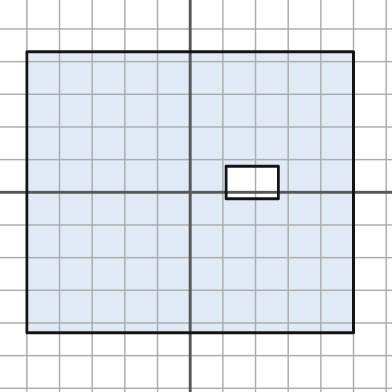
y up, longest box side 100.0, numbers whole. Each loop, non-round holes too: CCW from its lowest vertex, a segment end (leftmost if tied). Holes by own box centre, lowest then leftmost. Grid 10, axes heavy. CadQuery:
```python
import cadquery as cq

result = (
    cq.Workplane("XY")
    .moveTo(-50.0, -43.0)
    .lineTo(50.0, -43.0)
    .lineTo(50.0, 43.0)
    .lineTo(-50.0, 43.0)
    .close()
    .moveTo(11.0, -2.0)
    .lineTo(27.0, -2.0)
    .lineTo(27.0, 8.0)
    .lineTo(11.0, 8.0)
    .close()
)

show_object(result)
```